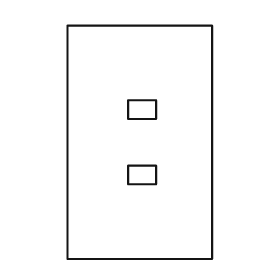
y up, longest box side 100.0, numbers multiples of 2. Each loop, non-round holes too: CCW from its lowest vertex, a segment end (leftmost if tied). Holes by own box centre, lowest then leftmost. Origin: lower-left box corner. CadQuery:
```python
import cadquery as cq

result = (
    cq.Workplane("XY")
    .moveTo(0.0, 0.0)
    .lineTo(62.0, 0.0)
    .lineTo(62.0, 100.0)
    .lineTo(0.0, 100.0)
    .close()
    .moveTo(26.0, 32.0)
    .lineTo(38.0, 32.0)
    .lineTo(38.0, 40.0)
    .lineTo(26.0, 40.0)
    .close()
    .moveTo(26.0, 60.0)
    .lineTo(38.0, 60.0)
    .lineTo(38.0, 68.0)
    .lineTo(26.0, 68.0)
    .close()
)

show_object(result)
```